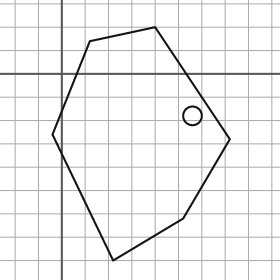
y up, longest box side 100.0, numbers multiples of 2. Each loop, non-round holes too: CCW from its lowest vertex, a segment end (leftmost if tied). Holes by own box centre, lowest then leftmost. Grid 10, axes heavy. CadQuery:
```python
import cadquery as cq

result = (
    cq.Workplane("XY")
    .moveTo(22.0, -80.0)
    .lineTo(52.0, -62.0)
    .lineTo(72.0, -28.0)
    .lineTo(40.0, 20.0)
    .lineTo(12.0, 14.0)
    .lineTo(-4.0, -26.0)
    .close()
    .moveTo(56.0, -18.0)
    .circle(4.0)
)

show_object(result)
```